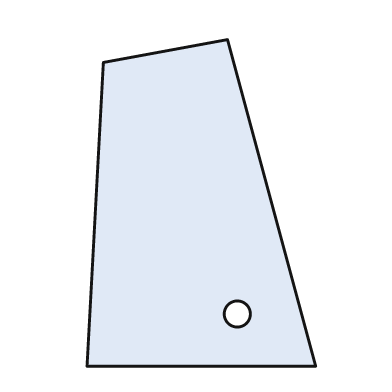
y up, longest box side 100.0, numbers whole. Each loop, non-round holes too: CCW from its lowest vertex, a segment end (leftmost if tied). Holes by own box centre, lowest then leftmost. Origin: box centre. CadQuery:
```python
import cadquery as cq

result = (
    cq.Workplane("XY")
    .moveTo(-35.0, -50.0)
    .lineTo(35.0, -50.0)
    .lineTo(8.0, 50.0)
    .lineTo(-30.0, 43.0)
    .close()
    .moveTo(11.0, -34.0)
    .circle(4.0)
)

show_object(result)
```